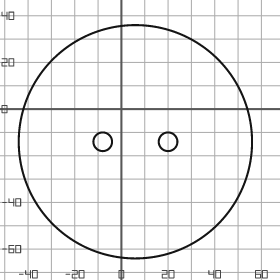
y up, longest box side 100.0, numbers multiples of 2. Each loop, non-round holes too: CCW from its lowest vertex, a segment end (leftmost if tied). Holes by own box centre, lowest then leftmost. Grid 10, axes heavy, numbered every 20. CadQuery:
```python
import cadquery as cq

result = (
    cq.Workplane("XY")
    .moveTo(6.0, -14.0)
    .circle(50.0)
    .moveTo(-8.0, -14.0)
    .circle(4.0)
    .moveTo(20.0, -14.0)
    .circle(4.0)
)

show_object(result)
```